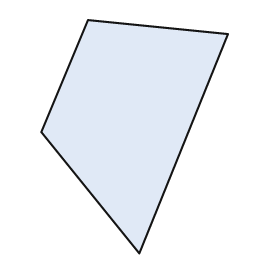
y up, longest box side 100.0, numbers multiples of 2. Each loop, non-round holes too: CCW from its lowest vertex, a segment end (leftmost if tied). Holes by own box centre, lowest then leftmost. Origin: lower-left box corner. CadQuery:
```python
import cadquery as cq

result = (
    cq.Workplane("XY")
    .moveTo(42.0, 0.0)
    .lineTo(80.0, 94.0)
    .lineTo(20.0, 100.0)
    .lineTo(0.0, 52.0)
    .close()
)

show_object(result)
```